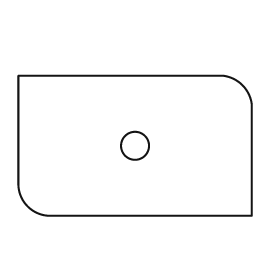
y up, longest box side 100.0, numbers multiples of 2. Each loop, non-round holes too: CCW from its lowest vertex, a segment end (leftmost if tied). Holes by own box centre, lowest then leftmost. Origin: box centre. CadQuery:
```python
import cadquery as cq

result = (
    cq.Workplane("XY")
    .moveTo(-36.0, -30.0)
    .lineTo(50.0, -30.0)
    .lineTo(50.0, 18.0)
    .threePointArc((46.0, 26.0), (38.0, 30.0))
    .lineTo(-50.0, 30.0)
    .lineTo(-50.0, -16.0)
    .threePointArc((-46.0, -26.0), (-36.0, -30.0))
    .close()
    .moveTo(0.0, 0.0)
    .circle(6.0)
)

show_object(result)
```